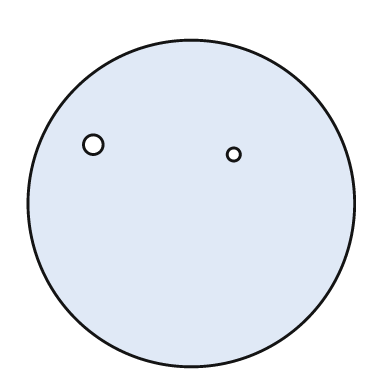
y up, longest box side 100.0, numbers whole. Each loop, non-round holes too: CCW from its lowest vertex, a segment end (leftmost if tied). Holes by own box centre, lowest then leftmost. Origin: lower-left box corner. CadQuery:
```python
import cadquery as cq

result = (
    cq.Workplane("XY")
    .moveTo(50.0, 50.0)
    .circle(50.0)
    .moveTo(63.0, 65.0)
    .circle(2.0)
    .moveTo(20.0, 68.0)
    .circle(3.0)
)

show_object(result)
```